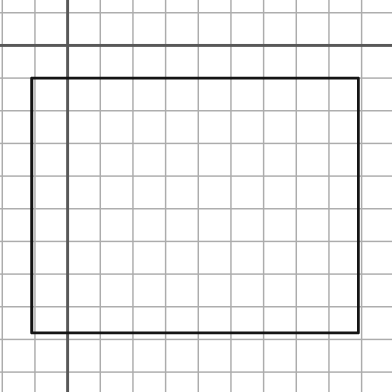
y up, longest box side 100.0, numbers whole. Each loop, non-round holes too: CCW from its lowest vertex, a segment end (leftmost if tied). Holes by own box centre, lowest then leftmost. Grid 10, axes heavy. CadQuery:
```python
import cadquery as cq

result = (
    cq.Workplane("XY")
    .moveTo(-11.0, -88.0)
    .lineTo(89.0, -88.0)
    .lineTo(89.0, -10.0)
    .lineTo(-11.0, -10.0)
    .close()
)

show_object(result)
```